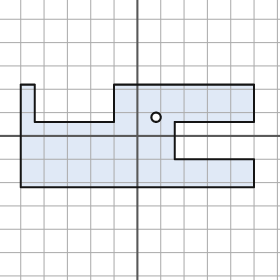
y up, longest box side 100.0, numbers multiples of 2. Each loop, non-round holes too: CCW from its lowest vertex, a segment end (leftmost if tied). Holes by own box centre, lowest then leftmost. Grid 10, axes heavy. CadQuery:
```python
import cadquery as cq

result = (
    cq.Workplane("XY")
    .moveTo(-50.0, -22.0)
    .lineTo(50.0, -22.0)
    .lineTo(50.0, -10.0)
    .lineTo(16.0, -10.0)
    .lineTo(16.0, 6.0)
    .lineTo(50.0, 6.0)
    .lineTo(50.0, 22.0)
    .lineTo(-10.0, 22.0)
    .lineTo(-10.0, 6.0)
    .lineTo(-44.0, 6.0)
    .lineTo(-44.0, 22.0)
    .lineTo(-50.0, 22.0)
    .close()
    .moveTo(8.0, 8.0)
    .circle(2.0)
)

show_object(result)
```